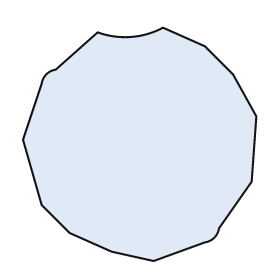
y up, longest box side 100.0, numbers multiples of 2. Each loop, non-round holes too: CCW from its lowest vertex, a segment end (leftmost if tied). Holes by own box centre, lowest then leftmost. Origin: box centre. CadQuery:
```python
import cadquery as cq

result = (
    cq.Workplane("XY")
    .moveTo(6.0, -50.0)
    .lineTo(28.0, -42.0)
    .threePointArc((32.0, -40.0), (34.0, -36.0))
    .lineTo(48.0, -16.0)
    .lineTo(50.0, 12.0)
    .lineTo(40.0, 30.0)
    .lineTo(28.0, 42.0)
    .lineTo(10.0, 50.0)
    .threePointArc((-4.0, 46.0), (-18.0, 48.0))
    .lineTo(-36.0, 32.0)
    .threePointArc((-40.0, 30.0), (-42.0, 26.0))
    .lineTo(-50.0, 2.0)
    .lineTo(-42.0, -26.0)
    .lineTo(-30.0, -38.0)
    .lineTo(-12.0, -46.0)
    .close()
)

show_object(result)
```